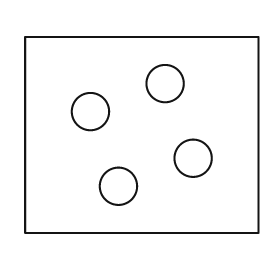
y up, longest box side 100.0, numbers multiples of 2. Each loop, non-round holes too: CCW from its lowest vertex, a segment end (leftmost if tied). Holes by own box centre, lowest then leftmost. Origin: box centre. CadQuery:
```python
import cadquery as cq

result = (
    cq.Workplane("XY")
    .moveTo(-50.0, -42.0)
    .lineTo(50.0, -42.0)
    .lineTo(50.0, 42.0)
    .lineTo(-50.0, 42.0)
    .close()
    .moveTo(-10.0, -22.0)
    .circle(8.0)
    .moveTo(22.0, -10.0)
    .circle(8.0)
    .moveTo(-22.0, 10.0)
    .circle(8.0)
    .moveTo(10.0, 22.0)
    .circle(8.0)
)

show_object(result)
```